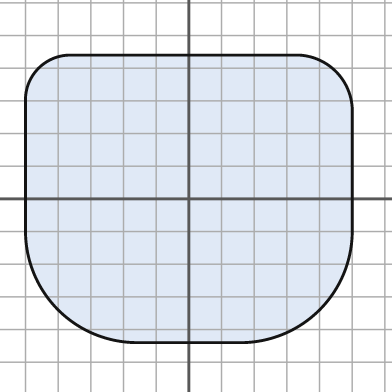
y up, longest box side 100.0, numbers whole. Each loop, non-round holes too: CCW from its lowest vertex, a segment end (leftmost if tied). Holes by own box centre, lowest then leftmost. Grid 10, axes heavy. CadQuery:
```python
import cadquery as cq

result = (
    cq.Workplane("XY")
    .moveTo(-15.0, -44.0)
    .lineTo(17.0, -44.0)
    .threePointArc((40.0, -34.0), (50.0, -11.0))
    .lineTo(50.0, 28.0)
    .threePointArc((45.0, 39.0), (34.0, 44.0))
    .lineTo(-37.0, 44.0)
    .threePointArc((-46.0, 40.0), (-50.0, 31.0))
    .lineTo(-50.0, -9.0)
    .threePointArc((-40.0, -34.0), (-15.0, -44.0))
    .close()
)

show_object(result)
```